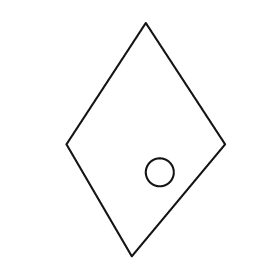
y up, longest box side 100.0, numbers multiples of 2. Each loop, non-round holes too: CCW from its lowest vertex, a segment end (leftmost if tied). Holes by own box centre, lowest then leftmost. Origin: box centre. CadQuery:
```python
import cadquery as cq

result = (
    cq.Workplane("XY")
    .moveTo(-6.0, -50.0)
    .lineTo(34.0, -2.0)
    .lineTo(0.0, 50.0)
    .lineTo(-34.0, -2.0)
    .close()
    .moveTo(6.0, -14.0)
    .circle(6.0)
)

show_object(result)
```